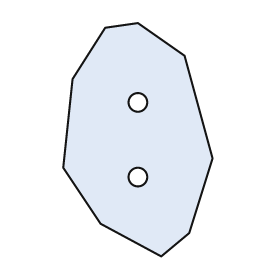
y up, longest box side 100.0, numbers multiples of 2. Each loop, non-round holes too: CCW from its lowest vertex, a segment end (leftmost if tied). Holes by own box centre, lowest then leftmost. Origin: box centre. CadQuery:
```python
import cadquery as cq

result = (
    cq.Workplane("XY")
    .moveTo(10.0, -50.0)
    .lineTo(22.0, -40.0)
    .lineTo(32.0, -8.0)
    .lineTo(20.0, 36.0)
    .lineTo(0.0, 50.0)
    .lineTo(-14.0, 48.0)
    .lineTo(-28.0, 26.0)
    .lineTo(-32.0, -12.0)
    .lineTo(-16.0, -36.0)
    .close()
    .moveTo(0.0, -16.0)
    .circle(4.0)
    .moveTo(0.0, 16.0)
    .circle(4.0)
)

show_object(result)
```